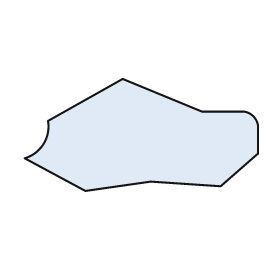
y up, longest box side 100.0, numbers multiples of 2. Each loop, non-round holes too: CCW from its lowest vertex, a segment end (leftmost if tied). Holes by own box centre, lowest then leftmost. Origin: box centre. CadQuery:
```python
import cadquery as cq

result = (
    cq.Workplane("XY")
    .moveTo(-24.0, -24.0)
    .lineTo(4.0, -20.0)
    .lineTo(34.0, -22.0)
    .lineTo(50.0, -8.0)
    .lineTo(50.0, 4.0)
    .threePointArc((48.0, 8.0), (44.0, 10.0))
    .lineTo(26.0, 10.0)
    .lineTo(-8.0, 24.0)
    .lineTo(-40.0, 6.0)
    .threePointArc((-42.0, -4.0), (-50.0, -10.0))
    .close()
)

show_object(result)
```